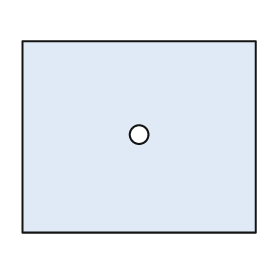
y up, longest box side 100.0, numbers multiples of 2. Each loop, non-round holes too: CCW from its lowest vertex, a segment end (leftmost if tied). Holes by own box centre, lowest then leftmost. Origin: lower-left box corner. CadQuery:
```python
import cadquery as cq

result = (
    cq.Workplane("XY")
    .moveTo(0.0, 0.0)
    .lineTo(100.0, 0.0)
    .lineTo(100.0, 82.0)
    .lineTo(0.0, 82.0)
    .close()
    .moveTo(50.0, 42.0)
    .circle(4.0)
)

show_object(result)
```